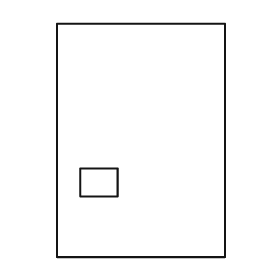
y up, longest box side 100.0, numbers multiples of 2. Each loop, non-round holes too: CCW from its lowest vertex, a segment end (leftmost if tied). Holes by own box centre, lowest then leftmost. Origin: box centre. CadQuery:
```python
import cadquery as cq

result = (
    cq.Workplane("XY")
    .moveTo(-36.0, -50.0)
    .lineTo(36.0, -50.0)
    .lineTo(36.0, 50.0)
    .lineTo(-36.0, 50.0)
    .close()
    .moveTo(-26.0, -24.0)
    .lineTo(-10.0, -24.0)
    .lineTo(-10.0, -12.0)
    .lineTo(-26.0, -12.0)
    .close()
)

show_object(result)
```